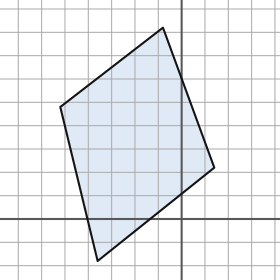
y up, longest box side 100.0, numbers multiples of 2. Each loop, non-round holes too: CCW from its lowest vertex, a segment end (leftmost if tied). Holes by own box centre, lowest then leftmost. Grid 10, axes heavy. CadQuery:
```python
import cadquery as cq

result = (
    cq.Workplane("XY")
    .moveTo(-36.0, -18.0)
    .lineTo(14.0, 22.0)
    .lineTo(-8.0, 82.0)
    .lineTo(-52.0, 48.0)
    .close()
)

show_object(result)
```